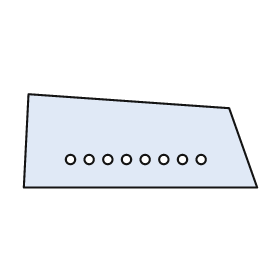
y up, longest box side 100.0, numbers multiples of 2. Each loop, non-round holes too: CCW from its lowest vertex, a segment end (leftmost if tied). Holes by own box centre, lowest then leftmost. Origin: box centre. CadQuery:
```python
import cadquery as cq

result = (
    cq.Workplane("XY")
    .moveTo(-50.0, -20.0)
    .lineTo(50.0, -20.0)
    .lineTo(38.0, 14.0)
    .lineTo(-48.0, 20.0)
    .close()
    .moveTo(-30.0, -8.0)
    .circle(2.0)
    .moveTo(-22.0, -8.0)
    .circle(2.0)
    .moveTo(-14.0, -8.0)
    .circle(2.0)
    .moveTo(-6.0, -8.0)
    .circle(2.0)
    .moveTo(2.0, -8.0)
    .circle(2.0)
    .moveTo(10.0, -8.0)
    .circle(2.0)
    .moveTo(18.0, -8.0)
    .circle(2.0)
    .moveTo(26.0, -8.0)
    .circle(2.0)
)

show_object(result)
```